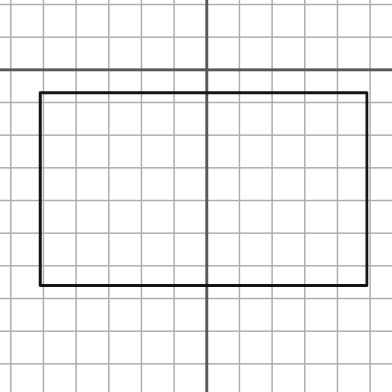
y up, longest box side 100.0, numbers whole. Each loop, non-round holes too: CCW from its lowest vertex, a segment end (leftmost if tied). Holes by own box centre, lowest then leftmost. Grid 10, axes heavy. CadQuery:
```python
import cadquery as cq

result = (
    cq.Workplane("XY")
    .moveTo(-51.0, -66.0)
    .lineTo(49.0, -66.0)
    .lineTo(49.0, -7.0)
    .lineTo(-51.0, -7.0)
    .close()
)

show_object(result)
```